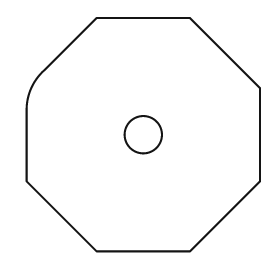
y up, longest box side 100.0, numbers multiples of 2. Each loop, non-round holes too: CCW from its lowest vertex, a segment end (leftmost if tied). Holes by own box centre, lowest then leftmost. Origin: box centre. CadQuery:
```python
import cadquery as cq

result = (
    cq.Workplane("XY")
    .moveTo(-20.0, -50.0)
    .lineTo(20.0, -50.0)
    .lineTo(50.0, -20.0)
    .lineTo(50.0, 20.0)
    .lineTo(20.0, 50.0)
    .lineTo(-20.0, 50.0)
    .lineTo(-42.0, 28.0)
    .threePointArc((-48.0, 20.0), (-50.0, 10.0))
    .lineTo(-50.0, -20.0)
    .close()
    .moveTo(0.0, 0.0)
    .circle(8.0)
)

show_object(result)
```